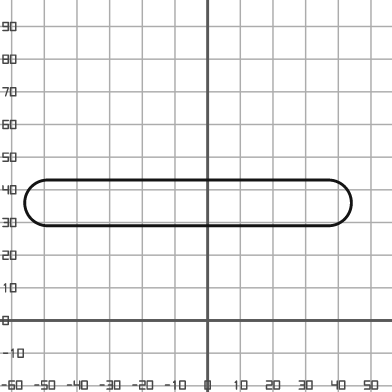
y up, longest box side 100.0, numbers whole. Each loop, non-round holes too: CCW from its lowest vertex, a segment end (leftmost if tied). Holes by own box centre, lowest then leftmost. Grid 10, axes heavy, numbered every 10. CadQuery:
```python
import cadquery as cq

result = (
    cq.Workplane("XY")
    .moveTo(-49.0, 29.0)
    .lineTo(37.0, 29.0)
    .threePointArc((44.0, 36.0), (37.0, 43.0))
    .lineTo(-49.0, 43.0)
    .threePointArc((-56.0, 36.0), (-49.0, 29.0))
    .close()
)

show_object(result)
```